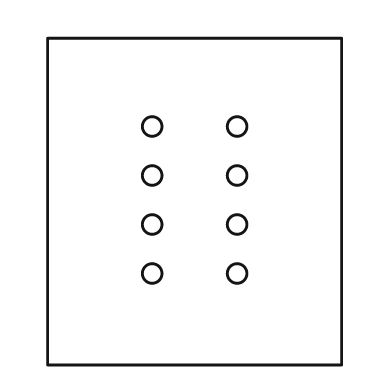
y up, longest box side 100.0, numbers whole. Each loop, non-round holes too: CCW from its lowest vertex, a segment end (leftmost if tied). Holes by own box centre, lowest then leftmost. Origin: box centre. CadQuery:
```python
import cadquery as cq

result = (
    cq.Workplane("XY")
    .moveTo(-45.0, -50.0)
    .lineTo(45.0, -50.0)
    .lineTo(45.0, 50.0)
    .lineTo(-45.0, 50.0)
    .close()
    .moveTo(-13.0, -22.0)
    .circle(3.0)
    .moveTo(13.0, -22.0)
    .circle(3.0)
    .moveTo(-13.0, -7.0)
    .circle(3.0)
    .moveTo(13.0, -7.0)
    .circle(3.0)
    .moveTo(-13.0, 8.0)
    .circle(3.0)
    .moveTo(13.0, 8.0)
    .circle(3.0)
    .moveTo(-13.0, 23.0)
    .circle(3.0)
    .moveTo(13.0, 23.0)
    .circle(3.0)
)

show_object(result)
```